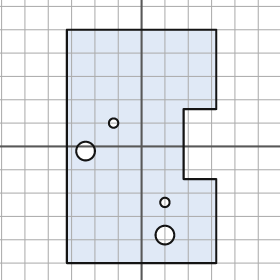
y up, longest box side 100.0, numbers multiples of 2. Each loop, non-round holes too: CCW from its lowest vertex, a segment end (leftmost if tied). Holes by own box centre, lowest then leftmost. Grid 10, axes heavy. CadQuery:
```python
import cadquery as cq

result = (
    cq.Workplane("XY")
    .moveTo(-32.0, -50.0)
    .lineTo(32.0, -50.0)
    .lineTo(32.0, -14.0)
    .lineTo(18.0, -14.0)
    .lineTo(18.0, 16.0)
    .lineTo(32.0, 16.0)
    .lineTo(32.0, 50.0)
    .lineTo(-32.0, 50.0)
    .close()
    .moveTo(10.0, -38.0)
    .circle(4.0)
    .moveTo(10.0, -24.0)
    .circle(2.0)
    .moveTo(-24.0, -2.0)
    .circle(4.0)
    .moveTo(-12.0, 10.0)
    .circle(2.0)
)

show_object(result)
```